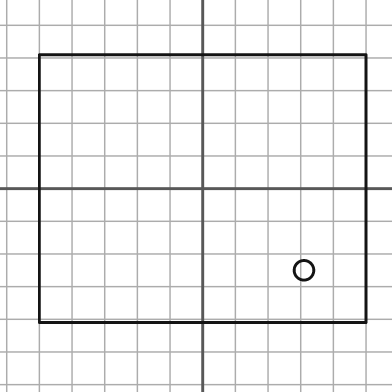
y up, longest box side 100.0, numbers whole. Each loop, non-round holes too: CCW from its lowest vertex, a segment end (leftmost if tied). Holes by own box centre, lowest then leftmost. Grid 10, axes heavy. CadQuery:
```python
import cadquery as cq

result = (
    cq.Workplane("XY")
    .moveTo(-50.0, -41.0)
    .lineTo(50.0, -41.0)
    .lineTo(50.0, 41.0)
    .lineTo(-50.0, 41.0)
    .close()
    .moveTo(31.0, -25.0)
    .circle(3.0)
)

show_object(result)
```